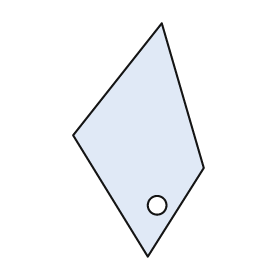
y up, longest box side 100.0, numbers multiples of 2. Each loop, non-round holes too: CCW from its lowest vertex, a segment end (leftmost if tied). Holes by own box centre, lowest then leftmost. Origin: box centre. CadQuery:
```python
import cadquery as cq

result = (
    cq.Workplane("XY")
    .moveTo(4.0, -50.0)
    .lineTo(28.0, -12.0)
    .lineTo(10.0, 50.0)
    .lineTo(-28.0, 2.0)
    .close()
    .moveTo(8.0, -28.0)
    .circle(4.0)
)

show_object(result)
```